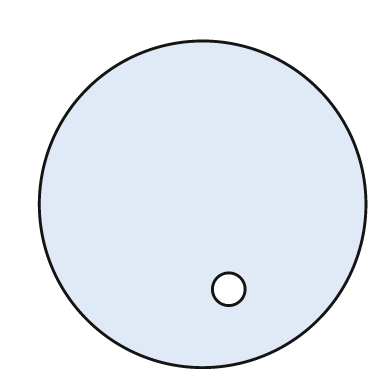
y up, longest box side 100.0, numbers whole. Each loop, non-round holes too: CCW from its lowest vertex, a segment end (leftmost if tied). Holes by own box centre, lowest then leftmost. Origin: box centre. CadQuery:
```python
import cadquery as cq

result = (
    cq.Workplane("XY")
    .moveTo(0.0, 0.0)
    .circle(50.0)
    .moveTo(8.0, -26.0)
    .circle(5.0)
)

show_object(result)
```